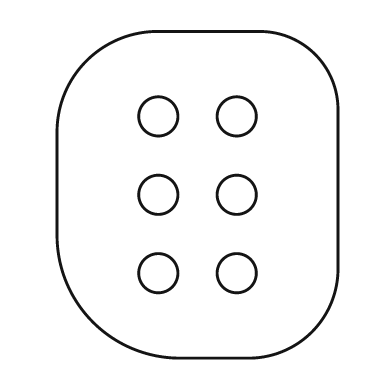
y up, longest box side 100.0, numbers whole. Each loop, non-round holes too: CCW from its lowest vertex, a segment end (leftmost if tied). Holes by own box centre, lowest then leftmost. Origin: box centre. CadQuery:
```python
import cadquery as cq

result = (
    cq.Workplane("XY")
    .moveTo(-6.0, -50.0)
    .lineTo(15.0, -50.0)
    .threePointArc((35.0, -42.0), (43.0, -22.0))
    .lineTo(43.0, 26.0)
    .threePointArc((36.0, 43.0), (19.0, 50.0))
    .lineTo(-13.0, 50.0)
    .threePointArc((-34.0, 41.0), (-43.0, 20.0))
    .lineTo(-43.0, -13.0)
    .threePointArc((-32.0, -39.0), (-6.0, -50.0))
    .close()
    .moveTo(-12.0, -24.0)
    .circle(6.0)
    .moveTo(12.0, -24.0)
    .circle(6.0)
    .moveTo(-12.0, 0.0)
    .circle(6.0)
    .moveTo(12.0, 0.0)
    .circle(6.0)
    .moveTo(-12.0, 24.0)
    .circle(6.0)
    .moveTo(12.0, 24.0)
    .circle(6.0)
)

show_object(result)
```